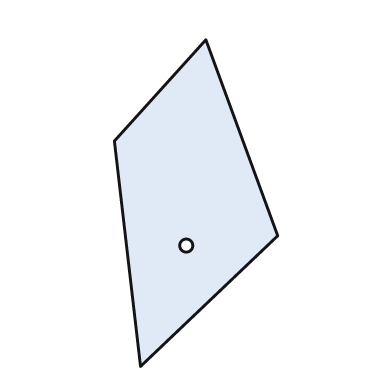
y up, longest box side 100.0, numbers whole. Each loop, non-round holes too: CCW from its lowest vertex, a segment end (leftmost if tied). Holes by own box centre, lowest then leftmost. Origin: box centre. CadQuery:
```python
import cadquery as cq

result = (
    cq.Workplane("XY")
    .moveTo(-17.0, -50.0)
    .lineTo(25.0, -10.0)
    .lineTo(3.0, 50.0)
    .lineTo(-25.0, 19.0)
    .close()
    .moveTo(-3.0, -13.0)
    .circle(2.0)
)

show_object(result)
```